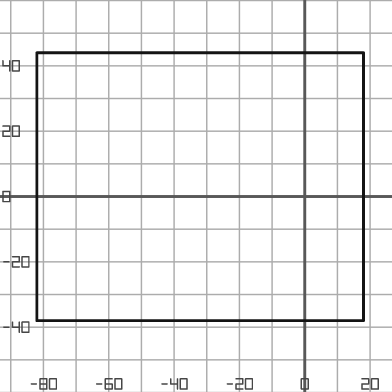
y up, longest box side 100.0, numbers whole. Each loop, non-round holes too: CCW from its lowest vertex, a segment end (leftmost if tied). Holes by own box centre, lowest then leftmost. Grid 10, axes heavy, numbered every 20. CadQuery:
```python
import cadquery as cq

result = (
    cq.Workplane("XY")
    .moveTo(-82.0, -38.0)
    .lineTo(18.0, -38.0)
    .lineTo(18.0, 44.0)
    .lineTo(-82.0, 44.0)
    .close()
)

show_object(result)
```